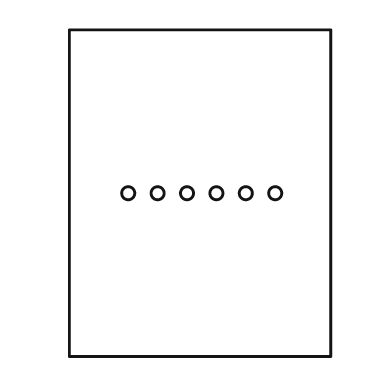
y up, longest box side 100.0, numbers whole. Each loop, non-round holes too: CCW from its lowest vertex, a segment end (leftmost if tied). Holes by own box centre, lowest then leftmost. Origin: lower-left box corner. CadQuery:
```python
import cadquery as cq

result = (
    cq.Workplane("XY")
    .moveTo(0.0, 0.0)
    .lineTo(80.0, 0.0)
    .lineTo(80.0, 100.0)
    .lineTo(0.0, 100.0)
    .close()
    .moveTo(18.0, 50.0)
    .circle(2.0)
    .moveTo(27.0, 50.0)
    .circle(2.0)
    .moveTo(36.0, 50.0)
    .circle(2.0)
    .moveTo(45.0, 50.0)
    .circle(2.0)
    .moveTo(54.0, 50.0)
    .circle(2.0)
    .moveTo(63.0, 50.0)
    .circle(2.0)
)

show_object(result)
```